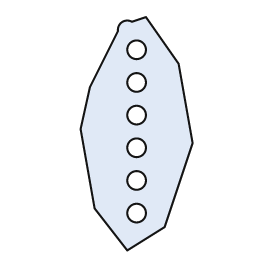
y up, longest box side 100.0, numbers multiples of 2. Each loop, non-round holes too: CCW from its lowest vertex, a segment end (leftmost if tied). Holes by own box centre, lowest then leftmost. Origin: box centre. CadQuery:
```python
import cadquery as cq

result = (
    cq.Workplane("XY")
    .moveTo(-4.0, -50.0)
    .lineTo(12.0, -40.0)
    .lineTo(24.0, -4.0)
    .lineTo(18.0, 30.0)
    .lineTo(4.0, 50.0)
    .lineTo(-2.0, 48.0)
    .threePointArc((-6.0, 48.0), (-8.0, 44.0))
    .lineTo(-20.0, 20.0)
    .lineTo(-24.0, 2.0)
    .lineTo(-18.0, -32.0)
    .close()
    .moveTo(0.0, -34.0)
    .circle(4.0)
    .moveTo(0.0, -20.0)
    .circle(4.0)
    .moveTo(0.0, -6.0)
    .circle(4.0)
    .moveTo(0.0, 8.0)
    .circle(4.0)
    .moveTo(0.0, 22.0)
    .circle(4.0)
    .moveTo(0.0, 36.0)
    .circle(4.0)
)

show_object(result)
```